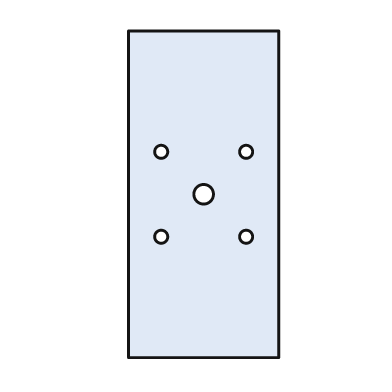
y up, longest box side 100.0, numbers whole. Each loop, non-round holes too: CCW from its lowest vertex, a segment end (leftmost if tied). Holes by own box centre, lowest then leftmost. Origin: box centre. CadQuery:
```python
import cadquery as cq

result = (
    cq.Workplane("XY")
    .moveTo(-23.0, -50.0)
    .lineTo(23.0, -50.0)
    .lineTo(23.0, 50.0)
    .lineTo(-23.0, 50.0)
    .close()
    .moveTo(-13.0, -13.0)
    .circle(2.0)
    .moveTo(13.0, -13.0)
    .circle(2.0)
    .moveTo(0.0, 0.0)
    .circle(3.0)
    .moveTo(-13.0, 13.0)
    .circle(2.0)
    .moveTo(13.0, 13.0)
    .circle(2.0)
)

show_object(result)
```